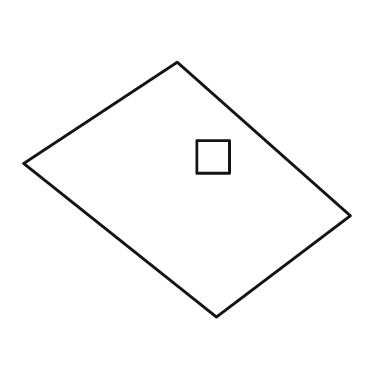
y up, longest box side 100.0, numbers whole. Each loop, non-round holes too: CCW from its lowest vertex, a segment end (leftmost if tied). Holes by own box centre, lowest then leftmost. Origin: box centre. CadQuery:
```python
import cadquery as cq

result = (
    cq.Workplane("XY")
    .moveTo(9.0, -39.0)
    .lineTo(50.0, -8.0)
    .lineTo(-3.0, 39.0)
    .lineTo(-50.0, 8.0)
    .close()
    .moveTo(3.0, 5.0)
    .lineTo(13.0, 5.0)
    .lineTo(13.0, 15.0)
    .lineTo(3.0, 15.0)
    .close()
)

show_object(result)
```